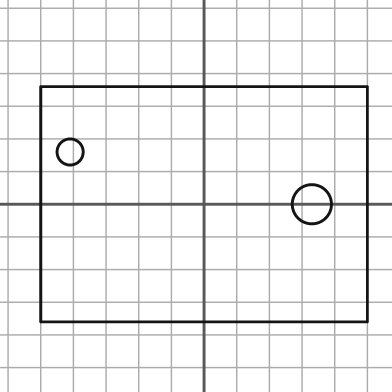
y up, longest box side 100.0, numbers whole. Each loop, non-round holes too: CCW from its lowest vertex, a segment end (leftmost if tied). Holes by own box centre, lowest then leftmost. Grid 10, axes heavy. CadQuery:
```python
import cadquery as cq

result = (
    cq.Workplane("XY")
    .moveTo(-50.0, -36.0)
    .lineTo(50.0, -36.0)
    .lineTo(50.0, 36.0)
    .lineTo(-50.0, 36.0)
    .close()
    .moveTo(33.0, 0.0)
    .circle(6.0)
    .moveTo(-41.0, 16.0)
    .circle(4.0)
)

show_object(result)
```